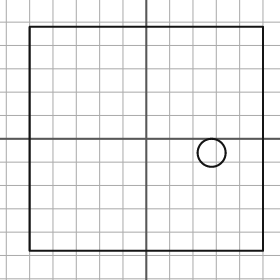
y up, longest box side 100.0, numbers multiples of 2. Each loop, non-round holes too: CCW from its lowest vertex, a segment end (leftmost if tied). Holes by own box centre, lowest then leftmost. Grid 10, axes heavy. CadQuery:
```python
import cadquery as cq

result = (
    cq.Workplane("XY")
    .moveTo(-50.0, -48.0)
    .lineTo(50.0, -48.0)
    .lineTo(50.0, 48.0)
    .lineTo(-50.0, 48.0)
    .close()
    .moveTo(28.0, -6.0)
    .circle(6.0)
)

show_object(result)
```